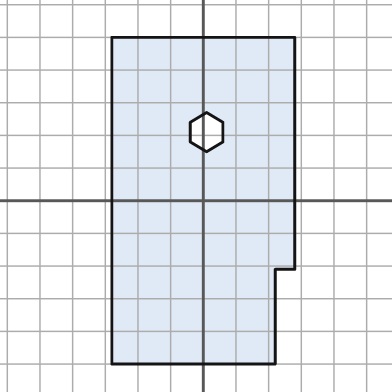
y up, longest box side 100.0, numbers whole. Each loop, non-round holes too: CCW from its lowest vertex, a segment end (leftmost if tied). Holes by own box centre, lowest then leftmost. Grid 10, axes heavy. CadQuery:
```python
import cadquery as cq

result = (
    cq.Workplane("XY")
    .moveTo(-28.0, -50.0)
    .lineTo(22.0, -50.0)
    .lineTo(22.0, -21.0)
    .lineTo(28.0, -21.0)
    .lineTo(28.0, 50.0)
    .lineTo(-28.0, 50.0)
    .close()
    .moveTo(1.0, 15.0)
    .lineTo(6.0, 18.0)
    .lineTo(6.0, 24.0)
    .lineTo(1.0, 27.0)
    .lineTo(-4.0, 24.0)
    .lineTo(-4.0, 18.0)
    .close()
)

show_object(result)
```